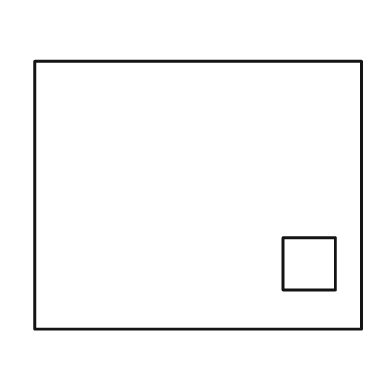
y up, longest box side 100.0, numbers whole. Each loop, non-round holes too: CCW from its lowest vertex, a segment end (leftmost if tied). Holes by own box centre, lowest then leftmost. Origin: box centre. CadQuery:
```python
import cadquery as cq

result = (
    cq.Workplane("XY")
    .moveTo(-50.0, -41.0)
    .lineTo(50.0, -41.0)
    .lineTo(50.0, 41.0)
    .lineTo(-50.0, 41.0)
    .close()
    .moveTo(26.0, -29.0)
    .lineTo(42.0, -29.0)
    .lineTo(42.0, -13.0)
    .lineTo(26.0, -13.0)
    .close()
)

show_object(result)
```